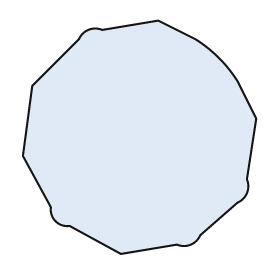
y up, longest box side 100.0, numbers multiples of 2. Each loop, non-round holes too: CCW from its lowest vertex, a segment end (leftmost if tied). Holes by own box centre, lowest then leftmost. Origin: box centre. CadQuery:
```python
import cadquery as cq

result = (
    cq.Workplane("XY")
    .moveTo(-8.0, -50.0)
    .lineTo(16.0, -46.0)
    .threePointArc((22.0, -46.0), (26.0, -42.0))
    .lineTo(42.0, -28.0)
    .threePointArc((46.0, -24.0), (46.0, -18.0))
    .lineTo(50.0, 8.0)
    .lineTo(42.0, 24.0)
    .threePointArc((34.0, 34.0), (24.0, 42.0))
    .lineTo(8.0, 50.0)
    .lineTo(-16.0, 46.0)
    .threePointArc((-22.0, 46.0), (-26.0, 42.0))
    .lineTo(-46.0, 22.0)
    .lineTo(-50.0, -8.0)
    .lineTo(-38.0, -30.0)
    .threePointArc((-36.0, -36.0), (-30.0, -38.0))
    .close()
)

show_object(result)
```